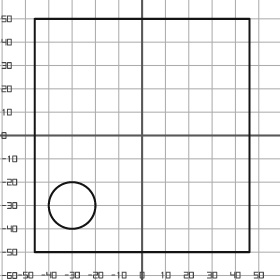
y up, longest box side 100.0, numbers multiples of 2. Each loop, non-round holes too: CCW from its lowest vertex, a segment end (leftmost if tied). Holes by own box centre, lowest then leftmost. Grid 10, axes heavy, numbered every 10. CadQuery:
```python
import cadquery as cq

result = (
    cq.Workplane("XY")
    .moveTo(-46.0, -50.0)
    .lineTo(46.0, -50.0)
    .lineTo(46.0, 50.0)
    .lineTo(-46.0, 50.0)
    .close()
    .moveTo(-30.0, -30.0)
    .circle(10.0)
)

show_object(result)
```